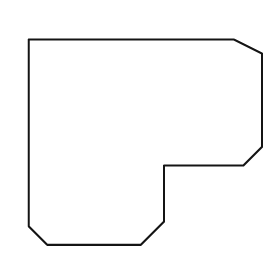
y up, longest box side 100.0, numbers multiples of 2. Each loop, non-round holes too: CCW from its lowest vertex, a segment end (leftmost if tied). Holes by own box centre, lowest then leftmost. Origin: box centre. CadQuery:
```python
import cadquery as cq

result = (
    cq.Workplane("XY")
    .moveTo(-42.0, -44.0)
    .lineTo(-2.0, -44.0)
    .lineTo(8.0, -34.0)
    .lineTo(8.0, -10.0)
    .lineTo(42.0, -10.0)
    .lineTo(50.0, -2.0)
    .lineTo(50.0, 38.0)
    .lineTo(38.0, 44.0)
    .lineTo(-50.0, 44.0)
    .lineTo(-50.0, -36.0)
    .close()
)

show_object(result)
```